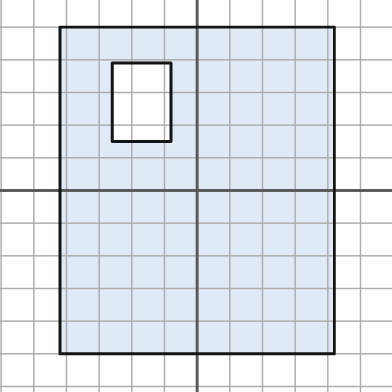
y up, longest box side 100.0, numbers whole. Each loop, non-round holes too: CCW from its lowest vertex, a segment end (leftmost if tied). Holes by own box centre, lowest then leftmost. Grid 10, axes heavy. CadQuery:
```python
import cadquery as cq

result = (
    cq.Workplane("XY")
    .moveTo(-42.0, -50.0)
    .lineTo(42.0, -50.0)
    .lineTo(42.0, 50.0)
    .lineTo(-42.0, 50.0)
    .close()
    .moveTo(-26.0, 15.0)
    .lineTo(-8.0, 15.0)
    .lineTo(-8.0, 39.0)
    .lineTo(-26.0, 39.0)
    .close()
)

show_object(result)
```